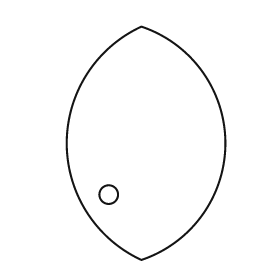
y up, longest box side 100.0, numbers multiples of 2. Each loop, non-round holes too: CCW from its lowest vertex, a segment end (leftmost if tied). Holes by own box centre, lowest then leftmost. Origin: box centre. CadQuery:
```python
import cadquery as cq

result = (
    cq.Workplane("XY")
    .moveTo(-2.0, -50.0)
    .threePointArc((34.0, 0.0), (-2.0, 50.0))
    .threePointArc((-34.0, 0.0), (-2.0, -50.0))
    .close()
    .moveTo(-16.0, -22.0)
    .circle(4.0)
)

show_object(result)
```